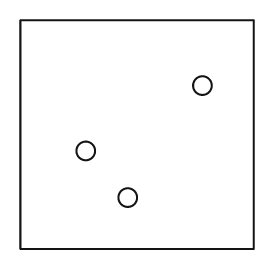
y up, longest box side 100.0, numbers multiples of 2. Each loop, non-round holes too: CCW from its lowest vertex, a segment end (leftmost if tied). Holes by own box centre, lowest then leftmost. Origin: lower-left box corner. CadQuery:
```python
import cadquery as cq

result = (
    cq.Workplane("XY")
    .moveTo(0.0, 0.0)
    .lineTo(100.0, 0.0)
    .lineTo(100.0, 98.0)
    .lineTo(0.0, 98.0)
    .close()
    .moveTo(46.0, 22.0)
    .circle(4.0)
    .moveTo(28.0, 42.0)
    .circle(4.0)
    .moveTo(78.0, 70.0)
    .circle(4.0)
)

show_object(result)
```